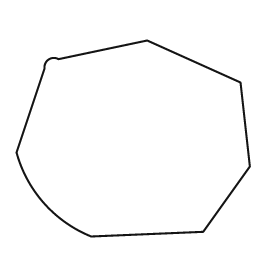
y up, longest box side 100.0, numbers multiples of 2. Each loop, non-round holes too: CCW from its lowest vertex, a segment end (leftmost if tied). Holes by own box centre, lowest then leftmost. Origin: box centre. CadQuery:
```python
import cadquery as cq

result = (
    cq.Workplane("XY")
    .moveTo(-18.0, -42.0)
    .lineTo(30.0, -40.0)
    .lineTo(50.0, -12.0)
    .lineTo(46.0, 24.0)
    .lineTo(6.0, 42.0)
    .lineTo(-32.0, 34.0)
    .threePointArc((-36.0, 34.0), (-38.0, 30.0))
    .lineTo(-50.0, -6.0)
    .threePointArc((-38.0, -28.0), (-18.0, -42.0))
    .close()
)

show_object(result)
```